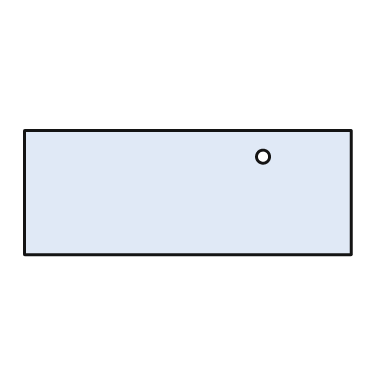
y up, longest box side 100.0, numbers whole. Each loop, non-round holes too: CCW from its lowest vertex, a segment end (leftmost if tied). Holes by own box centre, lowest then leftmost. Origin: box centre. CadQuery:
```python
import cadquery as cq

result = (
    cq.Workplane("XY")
    .moveTo(-50.0, -19.0)
    .lineTo(50.0, -19.0)
    .lineTo(50.0, 19.0)
    .lineTo(-50.0, 19.0)
    .close()
    .moveTo(23.0, 11.0)
    .circle(2.0)
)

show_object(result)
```